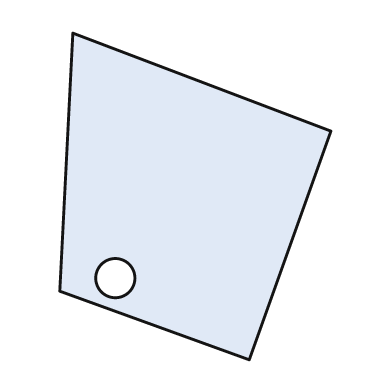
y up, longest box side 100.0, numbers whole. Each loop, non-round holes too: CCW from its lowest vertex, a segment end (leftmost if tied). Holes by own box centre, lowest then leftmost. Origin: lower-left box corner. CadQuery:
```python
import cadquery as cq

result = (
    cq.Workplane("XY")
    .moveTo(58.0, 0.0)
    .lineTo(83.0, 70.0)
    .lineTo(4.0, 100.0)
    .lineTo(0.0, 21.0)
    .close()
    .moveTo(17.0, 25.0)
    .circle(6.0)
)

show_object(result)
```